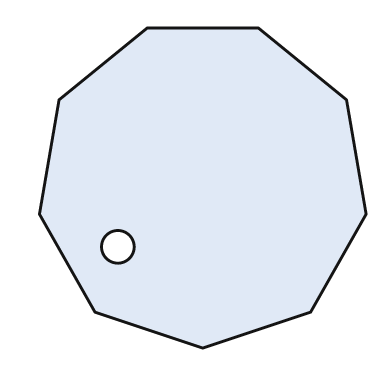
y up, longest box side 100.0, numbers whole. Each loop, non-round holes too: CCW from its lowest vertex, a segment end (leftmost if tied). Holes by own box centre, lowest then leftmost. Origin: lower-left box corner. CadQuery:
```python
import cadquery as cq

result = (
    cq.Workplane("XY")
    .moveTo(50.0, 0.0)
    .lineTo(83.0, 11.0)
    .lineTo(100.0, 41.0)
    .lineTo(94.0, 76.0)
    .lineTo(67.0, 98.0)
    .lineTo(33.0, 98.0)
    .lineTo(6.0, 76.0)
    .lineTo(0.0, 41.0)
    .lineTo(17.0, 11.0)
    .close()
    .moveTo(24.0, 31.0)
    .circle(5.0)
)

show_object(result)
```